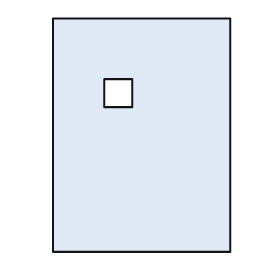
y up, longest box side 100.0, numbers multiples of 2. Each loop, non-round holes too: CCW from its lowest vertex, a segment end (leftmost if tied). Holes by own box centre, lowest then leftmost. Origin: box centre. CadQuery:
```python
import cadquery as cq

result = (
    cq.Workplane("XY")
    .moveTo(-38.0, -50.0)
    .lineTo(38.0, -50.0)
    .lineTo(38.0, 50.0)
    .lineTo(-38.0, 50.0)
    .close()
    .moveTo(-16.0, 12.0)
    .lineTo(-4.0, 12.0)
    .lineTo(-4.0, 24.0)
    .lineTo(-16.0, 24.0)
    .close()
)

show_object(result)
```